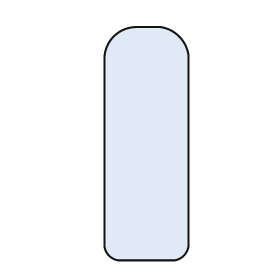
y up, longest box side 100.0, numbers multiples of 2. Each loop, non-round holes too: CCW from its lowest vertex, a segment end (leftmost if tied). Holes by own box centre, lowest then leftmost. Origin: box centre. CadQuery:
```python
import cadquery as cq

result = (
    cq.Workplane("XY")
    .moveTo(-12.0, -50.0)
    .lineTo(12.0, -50.0)
    .threePointArc((16.0, -48.0), (18.0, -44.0))
    .lineTo(18.0, 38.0)
    .threePointArc((14.0, 46.0), (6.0, 50.0))
    .lineTo(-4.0, 50.0)
    .threePointArc((-14.0, 46.0), (-18.0, 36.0))
    .lineTo(-18.0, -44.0)
    .threePointArc((-16.0, -48.0), (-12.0, -50.0))
    .close()
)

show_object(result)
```